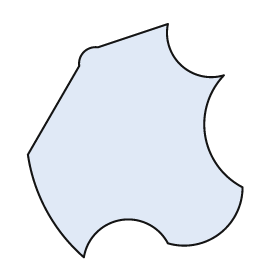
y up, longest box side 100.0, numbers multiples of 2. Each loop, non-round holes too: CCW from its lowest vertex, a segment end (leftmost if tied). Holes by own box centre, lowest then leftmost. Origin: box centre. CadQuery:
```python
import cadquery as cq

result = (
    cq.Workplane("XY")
    .moveTo(-22.0, -50.0)
    .threePointArc((-6.0, -34.0), (14.0, -44.0))
    .threePointArc((36.0, -40.0), (46.0, -20.0))
    .threePointArc((30.0, 2.0), (38.0, 28.0))
    .threePointArc((20.0, 32.0), (14.0, 50.0))
    .lineTo(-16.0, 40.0)
    .threePointArc((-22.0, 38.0), (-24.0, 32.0))
    .lineTo(-46.0, -6.0)
    .threePointArc((-38.0, -30.0), (-22.0, -50.0))
    .close()
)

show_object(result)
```